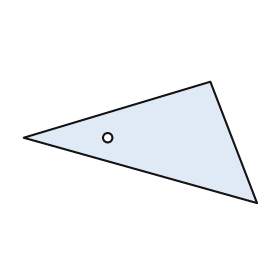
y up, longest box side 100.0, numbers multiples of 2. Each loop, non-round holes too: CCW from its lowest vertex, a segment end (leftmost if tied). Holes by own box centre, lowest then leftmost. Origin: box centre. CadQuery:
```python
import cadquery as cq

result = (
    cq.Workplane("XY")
    .moveTo(50.0, -26.0)
    .lineTo(30.0, 26.0)
    .lineTo(-50.0, 2.0)
    .close()
    .moveTo(-14.0, 2.0)
    .circle(2.0)
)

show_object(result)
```